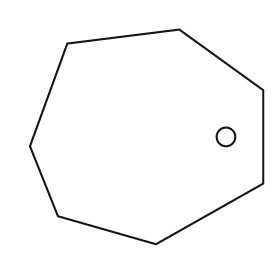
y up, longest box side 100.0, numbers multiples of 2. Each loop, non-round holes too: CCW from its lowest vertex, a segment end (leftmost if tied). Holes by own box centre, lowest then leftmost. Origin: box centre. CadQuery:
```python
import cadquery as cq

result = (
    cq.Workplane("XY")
    .moveTo(4.0, -46.0)
    .lineTo(50.0, -20.0)
    .lineTo(50.0, 20.0)
    .lineTo(14.0, 46.0)
    .lineTo(-34.0, 40.0)
    .lineTo(-50.0, -4.0)
    .lineTo(-38.0, -34.0)
    .close()
    .moveTo(34.0, 0.0)
    .circle(4.0)
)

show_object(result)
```